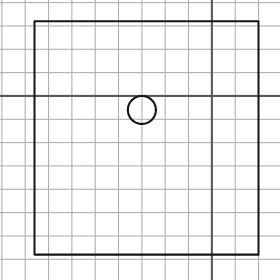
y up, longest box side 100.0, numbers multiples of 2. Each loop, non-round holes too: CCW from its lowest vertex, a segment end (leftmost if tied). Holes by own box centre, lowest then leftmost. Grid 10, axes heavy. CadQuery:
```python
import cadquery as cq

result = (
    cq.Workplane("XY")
    .moveTo(-76.0, -68.0)
    .lineTo(20.0, -68.0)
    .lineTo(20.0, 32.0)
    .lineTo(-76.0, 32.0)
    .close()
    .moveTo(-30.0, -6.0)
    .circle(6.0)
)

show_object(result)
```